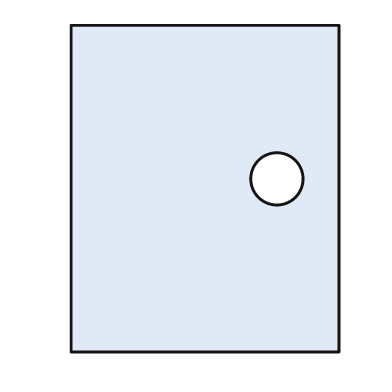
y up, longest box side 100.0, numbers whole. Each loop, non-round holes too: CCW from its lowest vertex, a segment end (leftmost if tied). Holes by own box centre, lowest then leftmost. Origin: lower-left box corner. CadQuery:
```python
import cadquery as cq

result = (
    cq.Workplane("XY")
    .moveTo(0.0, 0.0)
    .lineTo(82.0, 0.0)
    .lineTo(82.0, 100.0)
    .lineTo(0.0, 100.0)
    .close()
    .moveTo(63.0, 53.0)
    .circle(8.0)
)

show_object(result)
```